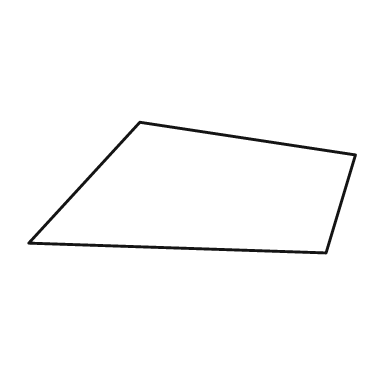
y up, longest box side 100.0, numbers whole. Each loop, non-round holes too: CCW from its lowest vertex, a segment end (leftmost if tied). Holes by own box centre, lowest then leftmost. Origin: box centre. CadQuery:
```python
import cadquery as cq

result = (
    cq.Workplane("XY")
    .moveTo(41.0, -20.0)
    .lineTo(50.0, 10.0)
    .lineTo(-16.0, 20.0)
    .lineTo(-50.0, -17.0)
    .close()
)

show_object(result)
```